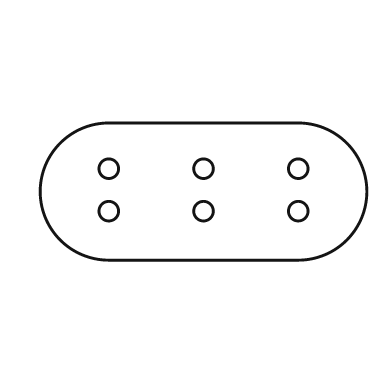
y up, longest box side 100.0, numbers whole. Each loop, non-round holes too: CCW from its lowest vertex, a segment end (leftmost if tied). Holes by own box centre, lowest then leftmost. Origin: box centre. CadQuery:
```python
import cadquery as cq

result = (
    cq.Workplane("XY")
    .moveTo(-29.0, -21.0)
    .lineTo(29.0, -21.0)
    .threePointArc((50.0, 0.0), (29.0, 21.0))
    .lineTo(-29.0, 21.0)
    .threePointArc((-50.0, 0.0), (-29.0, -21.0))
    .close()
    .moveTo(-29.0, -6.0)
    .circle(3.0)
    .moveTo(0.0, -6.0)
    .circle(3.0)
    .moveTo(29.0, -6.0)
    .circle(3.0)
    .moveTo(-29.0, 7.0)
    .circle(3.0)
    .moveTo(0.0, 7.0)
    .circle(3.0)
    .moveTo(29.0, 7.0)
    .circle(3.0)
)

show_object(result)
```